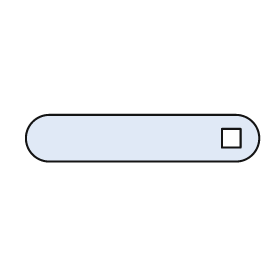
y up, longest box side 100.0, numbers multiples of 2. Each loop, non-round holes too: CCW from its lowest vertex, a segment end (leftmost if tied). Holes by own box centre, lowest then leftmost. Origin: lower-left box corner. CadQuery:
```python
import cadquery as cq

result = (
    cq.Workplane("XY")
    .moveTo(10.0, 0.0)
    .lineTo(90.0, 0.0)
    .threePointArc((100.0, 10.0), (90.0, 20.0))
    .lineTo(10.0, 20.0)
    .threePointArc((0.0, 10.0), (10.0, 0.0))
    .close()
    .moveTo(84.0, 6.0)
    .lineTo(92.0, 6.0)
    .lineTo(92.0, 14.0)
    .lineTo(84.0, 14.0)
    .close()
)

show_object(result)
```